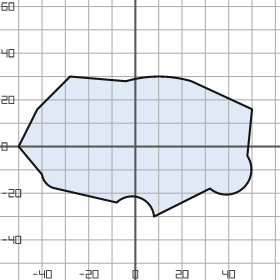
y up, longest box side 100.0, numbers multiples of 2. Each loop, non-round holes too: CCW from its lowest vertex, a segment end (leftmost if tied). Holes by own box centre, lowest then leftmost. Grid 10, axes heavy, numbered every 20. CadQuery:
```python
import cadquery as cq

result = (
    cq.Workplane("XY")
    .moveTo(8.0, -30.0)
    .lineTo(32.0, -18.0)
    .threePointArc((46.0, -18.0), (48.0, -4.0))
    .lineTo(50.0, 16.0)
    .lineTo(24.0, 28.0)
    .threePointArc((10.0, 30.0), (-4.0, 28.0))
    .lineTo(-28.0, 30.0)
    .lineTo(-42.0, 16.0)
    .lineTo(-50.0, 0.0)
    .lineTo(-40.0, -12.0)
    .threePointArc((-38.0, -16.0), (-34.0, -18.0))
    .lineTo(-8.0, -24.0)
    .threePointArc((2.0, -22.0), (8.0, -30.0))
    .close()
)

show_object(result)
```